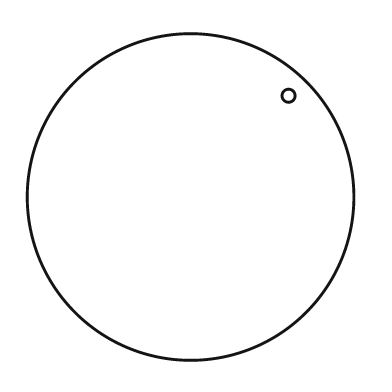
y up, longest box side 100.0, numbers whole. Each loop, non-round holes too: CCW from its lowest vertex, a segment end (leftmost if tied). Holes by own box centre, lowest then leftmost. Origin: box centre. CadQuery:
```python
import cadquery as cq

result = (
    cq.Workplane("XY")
    .moveTo(0.0, 0.0)
    .circle(50.0)
    .moveTo(30.0, 31.0)
    .circle(2.0)
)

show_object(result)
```